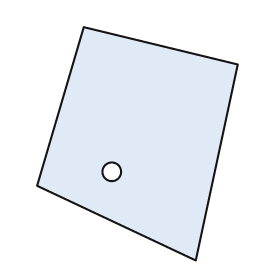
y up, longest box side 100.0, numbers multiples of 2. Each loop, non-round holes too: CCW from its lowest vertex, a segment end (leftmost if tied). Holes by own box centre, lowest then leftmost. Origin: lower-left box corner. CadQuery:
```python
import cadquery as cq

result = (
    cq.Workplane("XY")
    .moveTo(68.0, 0.0)
    .lineTo(86.0, 84.0)
    .lineTo(20.0, 100.0)
    .lineTo(0.0, 32.0)
    .close()
    .moveTo(32.0, 38.0)
    .circle(4.0)
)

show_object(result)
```